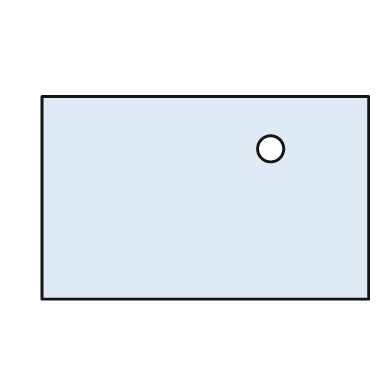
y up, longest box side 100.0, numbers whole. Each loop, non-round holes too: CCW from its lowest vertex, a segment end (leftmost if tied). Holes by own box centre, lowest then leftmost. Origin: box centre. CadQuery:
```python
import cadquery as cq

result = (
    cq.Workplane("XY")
    .moveTo(-50.0, -31.0)
    .lineTo(50.0, -31.0)
    .lineTo(50.0, 31.0)
    .lineTo(-50.0, 31.0)
    .close()
    .moveTo(20.0, 15.0)
    .circle(4.0)
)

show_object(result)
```